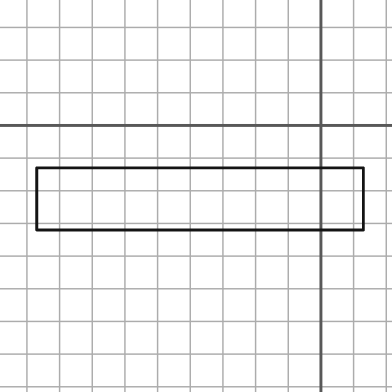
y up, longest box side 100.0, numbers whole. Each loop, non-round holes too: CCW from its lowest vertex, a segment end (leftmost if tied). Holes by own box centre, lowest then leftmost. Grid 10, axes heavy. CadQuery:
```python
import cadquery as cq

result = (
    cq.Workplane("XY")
    .moveTo(-87.0, -32.0)
    .lineTo(13.0, -32.0)
    .lineTo(13.0, -13.0)
    .lineTo(-87.0, -13.0)
    .close()
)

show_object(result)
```